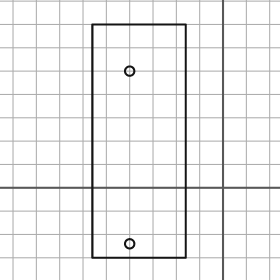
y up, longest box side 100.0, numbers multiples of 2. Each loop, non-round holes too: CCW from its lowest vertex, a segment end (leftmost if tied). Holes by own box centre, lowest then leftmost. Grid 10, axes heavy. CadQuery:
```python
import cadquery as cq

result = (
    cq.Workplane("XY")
    .moveTo(-56.0, -30.0)
    .lineTo(-16.0, -30.0)
    .lineTo(-16.0, 70.0)
    .lineTo(-56.0, 70.0)
    .close()
    .moveTo(-40.0, -24.0)
    .circle(2.0)
    .moveTo(-40.0, 50.0)
    .circle(2.0)
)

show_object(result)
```